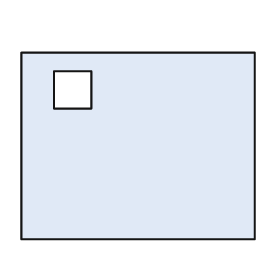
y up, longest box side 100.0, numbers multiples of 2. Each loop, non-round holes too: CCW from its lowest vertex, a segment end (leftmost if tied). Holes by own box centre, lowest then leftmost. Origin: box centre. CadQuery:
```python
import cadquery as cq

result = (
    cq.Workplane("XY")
    .moveTo(-50.0, -40.0)
    .lineTo(50.0, -40.0)
    .lineTo(50.0, 40.0)
    .lineTo(-50.0, 40.0)
    .close()
    .moveTo(-36.0, 16.0)
    .lineTo(-20.0, 16.0)
    .lineTo(-20.0, 32.0)
    .lineTo(-36.0, 32.0)
    .close()
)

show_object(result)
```